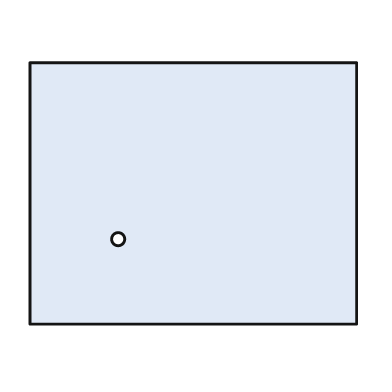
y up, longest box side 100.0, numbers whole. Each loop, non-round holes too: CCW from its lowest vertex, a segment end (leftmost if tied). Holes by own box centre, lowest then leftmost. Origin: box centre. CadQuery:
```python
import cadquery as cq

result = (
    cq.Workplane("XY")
    .moveTo(-50.0, -40.0)
    .lineTo(50.0, -40.0)
    .lineTo(50.0, 40.0)
    .lineTo(-50.0, 40.0)
    .close()
    .moveTo(-23.0, -14.0)
    .circle(2.0)
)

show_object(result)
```